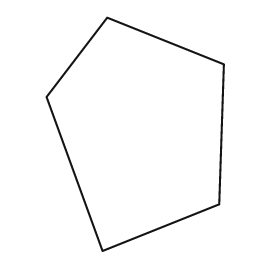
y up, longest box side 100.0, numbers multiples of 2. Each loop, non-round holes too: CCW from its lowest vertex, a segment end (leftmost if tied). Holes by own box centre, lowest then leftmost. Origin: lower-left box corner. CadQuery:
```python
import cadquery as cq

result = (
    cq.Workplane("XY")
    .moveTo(24.0, 0.0)
    .lineTo(74.0, 20.0)
    .lineTo(76.0, 80.0)
    .lineTo(26.0, 100.0)
    .lineTo(0.0, 66.0)
    .close()
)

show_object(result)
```